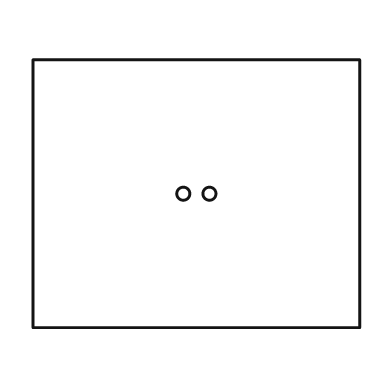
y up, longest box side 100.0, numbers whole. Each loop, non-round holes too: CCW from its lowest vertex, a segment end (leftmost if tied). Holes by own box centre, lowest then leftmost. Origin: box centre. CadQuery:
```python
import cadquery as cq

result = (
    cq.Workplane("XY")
    .moveTo(-50.0, -41.0)
    .lineTo(50.0, -41.0)
    .lineTo(50.0, 41.0)
    .lineTo(-50.0, 41.0)
    .close()
    .moveTo(-4.0, 0.0)
    .circle(2.0)
    .moveTo(4.0, 0.0)
    .circle(2.0)
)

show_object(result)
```